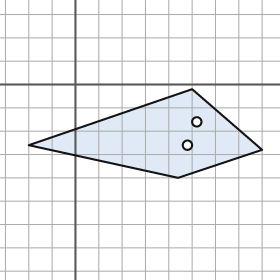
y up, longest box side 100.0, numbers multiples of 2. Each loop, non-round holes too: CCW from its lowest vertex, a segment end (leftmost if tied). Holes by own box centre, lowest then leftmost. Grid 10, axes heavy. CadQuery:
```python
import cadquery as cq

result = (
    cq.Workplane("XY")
    .moveTo(44.0, -40.0)
    .lineTo(80.0, -28.0)
    .lineTo(50.0, -2.0)
    .lineTo(-20.0, -26.0)
    .close()
    .moveTo(48.0, -26.0)
    .circle(2.0)
    .moveTo(52.0, -16.0)
    .circle(2.0)
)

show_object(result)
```